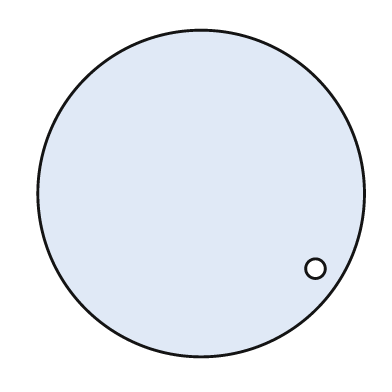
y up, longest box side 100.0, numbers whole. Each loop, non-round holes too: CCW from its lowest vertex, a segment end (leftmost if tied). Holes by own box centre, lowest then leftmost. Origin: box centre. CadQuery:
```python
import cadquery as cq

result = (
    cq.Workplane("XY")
    .moveTo(0.0, 0.0)
    .circle(50.0)
    .moveTo(35.0, -23.0)
    .circle(3.0)
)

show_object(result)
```